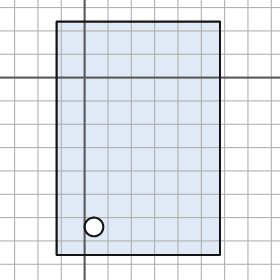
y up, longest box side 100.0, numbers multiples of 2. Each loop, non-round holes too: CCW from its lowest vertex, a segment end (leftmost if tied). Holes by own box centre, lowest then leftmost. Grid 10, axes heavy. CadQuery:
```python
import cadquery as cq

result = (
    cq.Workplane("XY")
    .moveTo(-12.0, -76.0)
    .lineTo(58.0, -76.0)
    .lineTo(58.0, 24.0)
    .lineTo(-12.0, 24.0)
    .close()
    .moveTo(4.0, -64.0)
    .circle(4.0)
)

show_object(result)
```